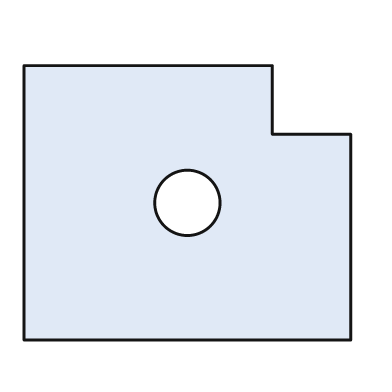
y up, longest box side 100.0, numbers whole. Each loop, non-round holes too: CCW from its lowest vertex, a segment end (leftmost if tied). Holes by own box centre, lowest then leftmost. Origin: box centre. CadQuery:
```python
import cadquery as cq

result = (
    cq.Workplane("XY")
    .moveTo(-50.0, -42.0)
    .lineTo(50.0, -42.0)
    .lineTo(50.0, 21.0)
    .lineTo(26.0, 21.0)
    .lineTo(26.0, 42.0)
    .lineTo(-50.0, 42.0)
    .close()
    .moveTo(0.0, 0.0)
    .circle(10.0)
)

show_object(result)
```